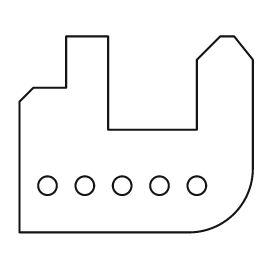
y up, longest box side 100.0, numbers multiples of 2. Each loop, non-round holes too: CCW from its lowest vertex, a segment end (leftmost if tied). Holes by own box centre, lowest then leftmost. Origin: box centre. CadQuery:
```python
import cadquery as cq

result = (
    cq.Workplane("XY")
    .moveTo(-50.0, -42.0)
    .lineTo(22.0, -42.0)
    .threePointArc((42.0, -34.0), (50.0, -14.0))
    .lineTo(50.0, 32.0)
    .lineTo(42.0, 42.0)
    .lineTo(36.0, 42.0)
    .lineTo(26.0, 32.0)
    .lineTo(26.0, 2.0)
    .lineTo(-12.0, 2.0)
    .lineTo(-12.0, 42.0)
    .lineTo(-30.0, 42.0)
    .lineTo(-30.0, 20.0)
    .lineTo(-44.0, 20.0)
    .lineTo(-50.0, 14.0)
    .close()
    .moveTo(-38.0, -22.0)
    .circle(4.0)
    .moveTo(-22.0, -22.0)
    .circle(4.0)
    .moveTo(-6.0, -22.0)
    .circle(4.0)
    .moveTo(10.0, -22.0)
    .circle(4.0)
    .moveTo(26.0, -22.0)
    .circle(4.0)
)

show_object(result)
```